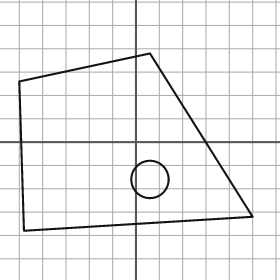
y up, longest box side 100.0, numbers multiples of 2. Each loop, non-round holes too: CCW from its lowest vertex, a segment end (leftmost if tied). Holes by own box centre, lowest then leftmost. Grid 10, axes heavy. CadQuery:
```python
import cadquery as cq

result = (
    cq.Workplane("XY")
    .moveTo(-48.0, -38.0)
    .lineTo(50.0, -32.0)
    .lineTo(6.0, 38.0)
    .lineTo(-50.0, 26.0)
    .close()
    .moveTo(6.0, -16.0)
    .circle(8.0)
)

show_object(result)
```